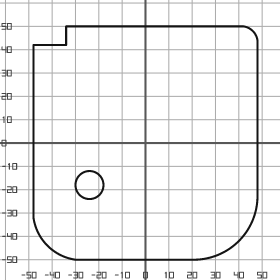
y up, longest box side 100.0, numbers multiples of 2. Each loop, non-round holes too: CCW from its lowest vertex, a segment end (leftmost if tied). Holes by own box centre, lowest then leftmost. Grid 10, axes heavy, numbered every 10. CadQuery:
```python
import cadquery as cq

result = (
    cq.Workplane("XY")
    .moveTo(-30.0, -50.0)
    .lineTo(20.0, -50.0)
    .threePointArc((40.0, -42.0), (48.0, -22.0))
    .lineTo(48.0, 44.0)
    .threePointArc((46.0, 48.0), (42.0, 50.0))
    .lineTo(-34.0, 50.0)
    .lineTo(-34.0, 42.0)
    .lineTo(-48.0, 42.0)
    .lineTo(-48.0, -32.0)
    .threePointArc((-42.0, -44.0), (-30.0, -50.0))
    .close()
    .moveTo(-24.0, -18.0)
    .circle(6.0)
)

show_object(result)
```